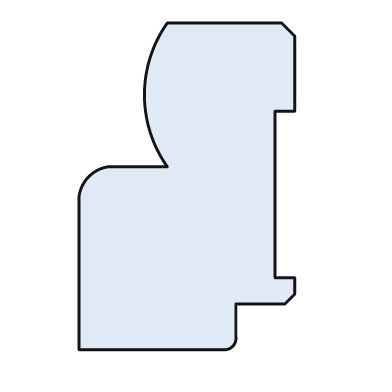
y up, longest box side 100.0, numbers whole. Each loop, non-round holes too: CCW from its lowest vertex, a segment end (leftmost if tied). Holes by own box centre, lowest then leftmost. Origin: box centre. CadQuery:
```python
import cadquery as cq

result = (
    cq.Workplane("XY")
    .moveTo(-33.0, -50.0)
    .lineTo(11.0, -50.0)
    .threePointArc((14.0, -49.0), (15.0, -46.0))
    .lineTo(15.0, -36.0)
    .lineTo(30.0, -36.0)
    .lineTo(33.0, -33.0)
    .lineTo(33.0, -28.0)
    .lineTo(27.0, -28.0)
    .lineTo(27.0, 23.0)
    .lineTo(33.0, 23.0)
    .lineTo(33.0, 46.0)
    .lineTo(29.0, 50.0)
    .lineTo(-6.0, 50.0)
    .threePointArc((-13.0, 28.0), (-6.0, 6.0))
    .lineTo(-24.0, 6.0)
    .threePointArc((-30.0, 3.0), (-33.0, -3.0))
    .close()
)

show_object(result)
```